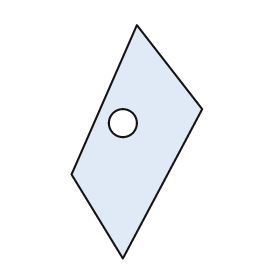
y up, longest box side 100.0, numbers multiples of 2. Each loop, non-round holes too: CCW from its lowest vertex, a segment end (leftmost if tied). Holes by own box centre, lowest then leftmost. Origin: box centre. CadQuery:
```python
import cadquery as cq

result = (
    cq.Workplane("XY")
    .moveTo(-6.0, -50.0)
    .lineTo(28.0, 14.0)
    .lineTo(0.0, 50.0)
    .lineTo(-28.0, -14.0)
    .close()
    .moveTo(-6.0, 8.0)
    .circle(6.0)
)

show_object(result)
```